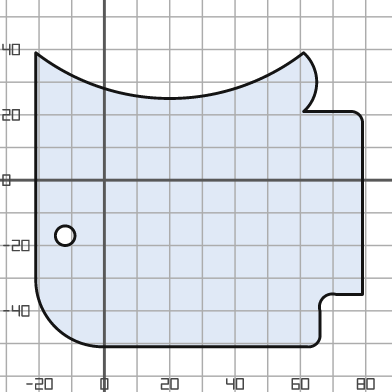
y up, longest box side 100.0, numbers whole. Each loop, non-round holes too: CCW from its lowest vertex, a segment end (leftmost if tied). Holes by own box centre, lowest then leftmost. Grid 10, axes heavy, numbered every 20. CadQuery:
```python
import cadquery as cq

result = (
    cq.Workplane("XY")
    .moveTo(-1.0, -51.0)
    .lineTo(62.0, -51.0)
    .threePointArc((65.0, -50.0), (66.0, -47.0))
    .lineTo(66.0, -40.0)
    .threePointArc((67.0, -36.0), (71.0, -35.0))
    .lineTo(79.0, -35.0)
    .lineTo(79.0, 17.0)
    .threePointArc((78.0, 20.0), (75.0, 21.0))
    .lineTo(61.0, 21.0)
    .threePointArc((65.0, 30.0), (61.0, 39.0))
    .threePointArc((20.0, 25.0), (-21.0, 39.0))
    .lineTo(-21.0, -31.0)
    .threePointArc((-15.0, -45.0), (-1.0, -51.0))
    .close()
    .moveTo(-12.0, -17.0)
    .circle(3.0)
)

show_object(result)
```